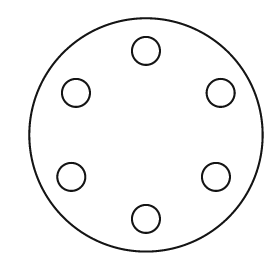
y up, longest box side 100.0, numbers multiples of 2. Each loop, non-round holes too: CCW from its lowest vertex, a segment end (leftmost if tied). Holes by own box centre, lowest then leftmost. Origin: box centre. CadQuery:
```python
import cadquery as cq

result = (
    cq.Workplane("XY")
    .moveTo(0.0, 0.0)
    .circle(50.0)
    .moveTo(0.0, -36.0)
    .circle(6.0)
    .moveTo(-32.0, -18.0)
    .circle(6.0)
    .moveTo(30.0, -18.0)
    .circle(6.0)
    .moveTo(-30.0, 18.0)
    .circle(6.0)
    .moveTo(32.0, 18.0)
    .circle(6.0)
    .moveTo(0.0, 36.0)
    .circle(6.0)
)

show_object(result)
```